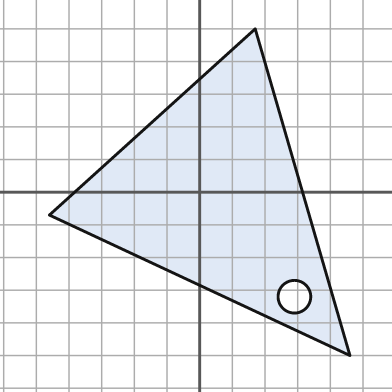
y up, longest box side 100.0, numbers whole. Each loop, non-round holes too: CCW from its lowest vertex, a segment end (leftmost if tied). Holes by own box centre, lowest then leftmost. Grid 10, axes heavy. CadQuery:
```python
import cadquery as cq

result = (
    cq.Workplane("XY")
    .moveTo(46.0, -50.0)
    .lineTo(17.0, 50.0)
    .lineTo(-46.0, -7.0)
    .close()
    .moveTo(29.0, -32.0)
    .circle(5.0)
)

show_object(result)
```